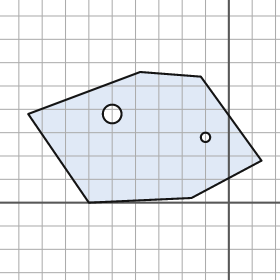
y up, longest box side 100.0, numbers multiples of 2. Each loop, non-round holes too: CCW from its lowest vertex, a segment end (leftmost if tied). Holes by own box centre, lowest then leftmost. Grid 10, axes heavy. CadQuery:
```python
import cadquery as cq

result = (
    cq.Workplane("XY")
    .moveTo(-60.0, 0.0)
    .lineTo(-16.0, 2.0)
    .lineTo(14.0, 18.0)
    .lineTo(-12.0, 54.0)
    .lineTo(-38.0, 56.0)
    .lineTo(-86.0, 38.0)
    .close()
    .moveTo(-10.0, 28.0)
    .circle(2.0)
    .moveTo(-50.0, 38.0)
    .circle(4.0)
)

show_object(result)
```